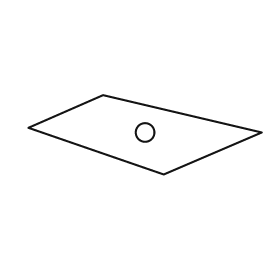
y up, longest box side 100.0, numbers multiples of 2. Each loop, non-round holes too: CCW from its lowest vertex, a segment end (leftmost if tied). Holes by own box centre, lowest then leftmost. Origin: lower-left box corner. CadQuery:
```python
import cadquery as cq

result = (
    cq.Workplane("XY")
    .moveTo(58.0, 0.0)
    .lineTo(100.0, 18.0)
    .lineTo(32.0, 34.0)
    .lineTo(0.0, 20.0)
    .close()
    .moveTo(50.0, 18.0)
    .circle(4.0)
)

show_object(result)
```